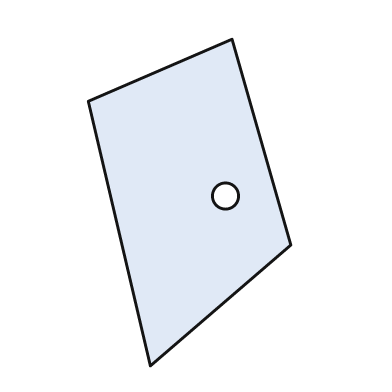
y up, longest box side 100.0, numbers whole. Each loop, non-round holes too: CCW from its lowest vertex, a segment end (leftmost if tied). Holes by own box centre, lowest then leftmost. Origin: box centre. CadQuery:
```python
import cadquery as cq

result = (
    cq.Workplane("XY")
    .moveTo(-12.0, -50.0)
    .lineTo(31.0, -13.0)
    .lineTo(13.0, 50.0)
    .lineTo(-31.0, 31.0)
    .close()
    .moveTo(11.0, 2.0)
    .circle(4.0)
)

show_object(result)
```